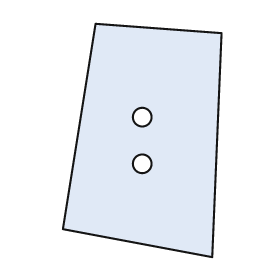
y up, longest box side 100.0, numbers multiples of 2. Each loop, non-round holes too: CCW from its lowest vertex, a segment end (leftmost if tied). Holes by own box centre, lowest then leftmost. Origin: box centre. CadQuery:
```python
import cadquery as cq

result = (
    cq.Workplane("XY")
    .moveTo(30.0, -50.0)
    .lineTo(34.0, 46.0)
    .lineTo(-20.0, 50.0)
    .lineTo(-34.0, -38.0)
    .close()
    .moveTo(0.0, -10.0)
    .circle(4.0)
    .moveTo(0.0, 10.0)
    .circle(4.0)
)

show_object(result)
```